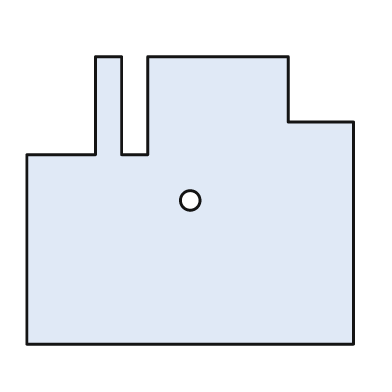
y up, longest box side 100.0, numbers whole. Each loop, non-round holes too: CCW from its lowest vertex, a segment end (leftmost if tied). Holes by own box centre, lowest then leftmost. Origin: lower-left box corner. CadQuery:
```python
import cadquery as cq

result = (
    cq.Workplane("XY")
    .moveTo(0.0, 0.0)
    .lineTo(100.0, 0.0)
    .lineTo(100.0, 68.0)
    .lineTo(80.0, 68.0)
    .lineTo(80.0, 88.0)
    .lineTo(37.0, 88.0)
    .lineTo(37.0, 58.0)
    .lineTo(29.0, 58.0)
    .lineTo(29.0, 88.0)
    .lineTo(21.0, 88.0)
    .lineTo(21.0, 58.0)
    .lineTo(0.0, 58.0)
    .close()
    .moveTo(50.0, 44.0)
    .circle(3.0)
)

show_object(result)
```